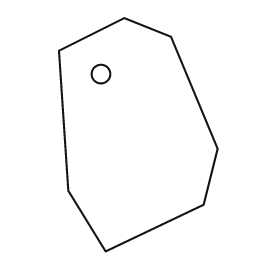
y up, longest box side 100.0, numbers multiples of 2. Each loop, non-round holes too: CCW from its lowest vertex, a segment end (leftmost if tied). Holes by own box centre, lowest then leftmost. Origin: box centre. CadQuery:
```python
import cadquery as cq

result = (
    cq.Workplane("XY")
    .moveTo(-14.0, -50.0)
    .lineTo(28.0, -30.0)
    .lineTo(34.0, -6.0)
    .lineTo(14.0, 42.0)
    .lineTo(-6.0, 50.0)
    .lineTo(-34.0, 36.0)
    .lineTo(-30.0, -24.0)
    .close()
    .moveTo(-16.0, 26.0)
    .circle(4.0)
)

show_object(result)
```